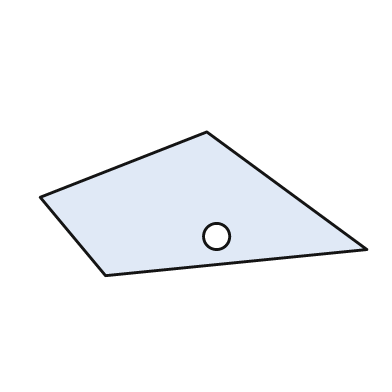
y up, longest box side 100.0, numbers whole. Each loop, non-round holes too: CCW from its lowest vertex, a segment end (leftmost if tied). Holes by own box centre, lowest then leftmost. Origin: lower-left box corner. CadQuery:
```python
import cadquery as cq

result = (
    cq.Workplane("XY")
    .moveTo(20.0, 0.0)
    .lineTo(100.0, 8.0)
    .lineTo(51.0, 44.0)
    .lineTo(0.0, 24.0)
    .close()
    .moveTo(54.0, 12.0)
    .circle(4.0)
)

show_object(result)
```